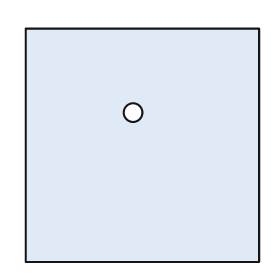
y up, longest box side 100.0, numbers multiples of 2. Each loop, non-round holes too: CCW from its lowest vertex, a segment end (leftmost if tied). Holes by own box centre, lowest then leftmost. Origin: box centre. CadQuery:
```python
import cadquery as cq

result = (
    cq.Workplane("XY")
    .moveTo(-50.0, -50.0)
    .lineTo(50.0, -50.0)
    .lineTo(50.0, 50.0)
    .lineTo(-50.0, 50.0)
    .close()
    .moveTo(-4.0, 14.0)
    .circle(4.0)
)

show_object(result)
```